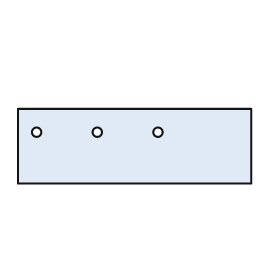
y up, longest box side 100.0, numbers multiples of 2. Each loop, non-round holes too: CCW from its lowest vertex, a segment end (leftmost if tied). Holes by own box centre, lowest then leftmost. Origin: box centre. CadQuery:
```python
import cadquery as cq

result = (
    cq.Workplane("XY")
    .moveTo(-50.0, -16.0)
    .lineTo(50.0, -16.0)
    .lineTo(50.0, 16.0)
    .lineTo(-50.0, 16.0)
    .close()
    .moveTo(-42.0, 6.0)
    .circle(2.0)
    .moveTo(-16.0, 6.0)
    .circle(2.0)
    .moveTo(10.0, 6.0)
    .circle(2.0)
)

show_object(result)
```